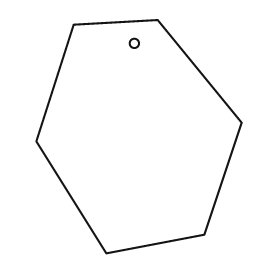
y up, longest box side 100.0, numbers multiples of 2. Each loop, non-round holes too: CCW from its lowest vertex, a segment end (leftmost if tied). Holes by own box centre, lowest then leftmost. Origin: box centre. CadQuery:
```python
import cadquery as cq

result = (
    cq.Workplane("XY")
    .moveTo(-14.0, -50.0)
    .lineTo(28.0, -42.0)
    .lineTo(44.0, 6.0)
    .lineTo(8.0, 50.0)
    .lineTo(-28.0, 48.0)
    .lineTo(-44.0, -2.0)
    .close()
    .moveTo(-2.0, 40.0)
    .circle(2.0)
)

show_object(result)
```